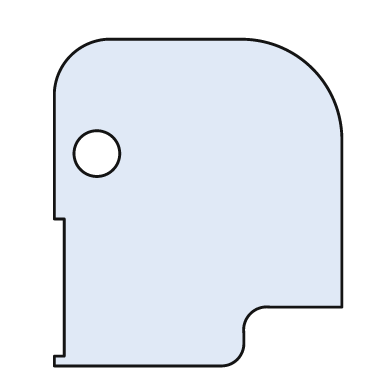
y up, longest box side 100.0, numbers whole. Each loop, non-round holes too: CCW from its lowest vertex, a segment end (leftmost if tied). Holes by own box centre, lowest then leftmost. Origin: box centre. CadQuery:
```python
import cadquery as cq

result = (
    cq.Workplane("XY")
    .moveTo(-44.0, -50.0)
    .lineTo(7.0, -50.0)
    .threePointArc((12.0, -48.0), (14.0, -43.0))
    .lineTo(14.0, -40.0)
    .threePointArc((16.0, -34.0), (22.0, -32.0))
    .lineTo(44.0, -32.0)
    .lineTo(44.0, 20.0)
    .threePointArc((35.0, 41.0), (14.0, 50.0))
    .lineTo(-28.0, 50.0)
    .threePointArc((-39.0, 45.0), (-44.0, 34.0))
    .lineTo(-44.0, -5.0)
    .lineTo(-41.0, -5.0)
    .lineTo(-41.0, -47.0)
    .lineTo(-44.0, -47.0)
    .close()
    .moveTo(-31.0, 15.0)
    .circle(7.0)
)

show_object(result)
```